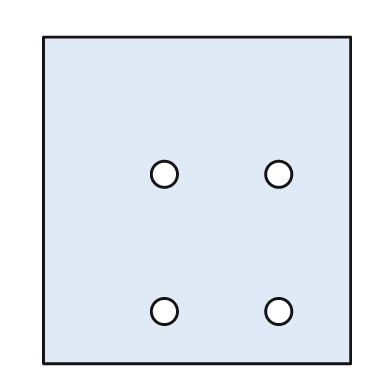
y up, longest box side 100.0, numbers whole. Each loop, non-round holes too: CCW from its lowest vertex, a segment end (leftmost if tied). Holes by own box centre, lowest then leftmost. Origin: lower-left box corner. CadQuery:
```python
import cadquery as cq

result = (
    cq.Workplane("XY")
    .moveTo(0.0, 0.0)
    .lineTo(94.0, 0.0)
    .lineTo(94.0, 100.0)
    .lineTo(0.0, 100.0)
    .close()
    .moveTo(37.0, 16.0)
    .circle(4.0)
    .moveTo(72.0, 16.0)
    .circle(4.0)
    .moveTo(37.0, 58.0)
    .circle(4.0)
    .moveTo(72.0, 58.0)
    .circle(4.0)
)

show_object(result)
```